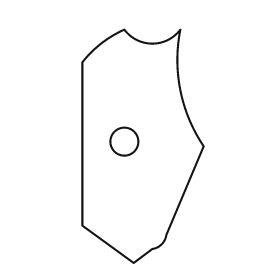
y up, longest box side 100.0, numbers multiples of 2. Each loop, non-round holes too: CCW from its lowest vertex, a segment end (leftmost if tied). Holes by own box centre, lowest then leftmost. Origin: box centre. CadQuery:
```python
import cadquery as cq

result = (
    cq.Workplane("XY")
    .moveTo(-4.0, -50.0)
    .lineTo(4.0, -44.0)
    .threePointArc((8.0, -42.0), (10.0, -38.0))
    .lineTo(26.0, 0.0)
    .threePointArc((16.0, 24.0), (16.0, 50.0))
    .threePointArc((4.0, 44.0), (-8.0, 50.0))
    .threePointArc((-18.0, 44.0), (-26.0, 36.0))
    .lineTo(-26.0, -34.0)
    .close()
    .moveTo(-8.0, 2.0)
    .circle(6.0)
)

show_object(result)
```